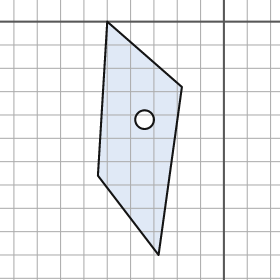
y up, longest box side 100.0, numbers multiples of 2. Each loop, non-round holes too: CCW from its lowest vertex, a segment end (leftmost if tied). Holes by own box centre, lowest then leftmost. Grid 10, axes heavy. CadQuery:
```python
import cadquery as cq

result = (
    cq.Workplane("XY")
    .moveTo(-28.0, -100.0)
    .lineTo(-18.0, -28.0)
    .lineTo(-50.0, 0.0)
    .lineTo(-54.0, -66.0)
    .close()
    .moveTo(-34.0, -42.0)
    .circle(4.0)
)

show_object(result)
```